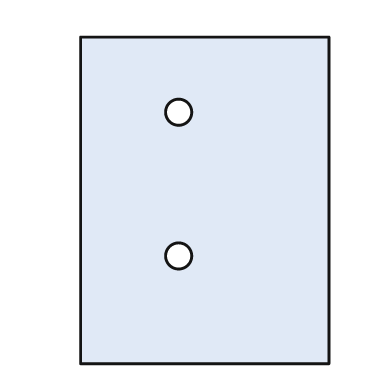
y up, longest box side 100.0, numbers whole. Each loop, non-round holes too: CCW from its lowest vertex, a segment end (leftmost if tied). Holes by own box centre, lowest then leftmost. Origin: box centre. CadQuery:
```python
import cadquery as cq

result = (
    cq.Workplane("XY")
    .moveTo(-38.0, -50.0)
    .lineTo(38.0, -50.0)
    .lineTo(38.0, 50.0)
    .lineTo(-38.0, 50.0)
    .close()
    .moveTo(-8.0, -17.0)
    .circle(4.0)
    .moveTo(-8.0, 27.0)
    .circle(4.0)
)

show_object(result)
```